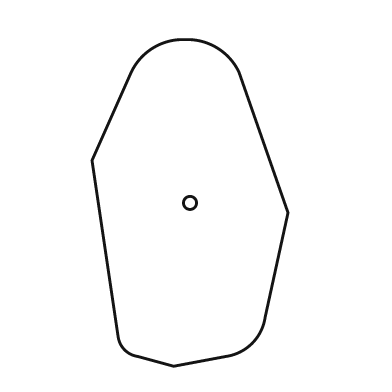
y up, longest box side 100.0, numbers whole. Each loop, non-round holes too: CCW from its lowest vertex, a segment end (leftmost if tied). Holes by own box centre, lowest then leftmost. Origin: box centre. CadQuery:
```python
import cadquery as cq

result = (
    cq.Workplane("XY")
    .moveTo(-5.0, -50.0)
    .lineTo(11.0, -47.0)
    .threePointArc((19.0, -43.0), (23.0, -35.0))
    .lineTo(30.0, -3.0)
    .lineTo(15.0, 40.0)
    .threePointArc((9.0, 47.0), (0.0, 50.0))
    .lineTo(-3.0, 50.0)
    .threePointArc((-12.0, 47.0), (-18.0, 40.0))
    .lineTo(-30.0, 13.0)
    .lineTo(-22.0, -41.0)
    .threePointArc((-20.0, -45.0), (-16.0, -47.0))
    .close()
    .moveTo(0.0, 0.0)
    .circle(2.0)
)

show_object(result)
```